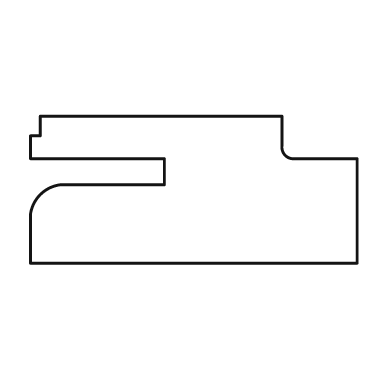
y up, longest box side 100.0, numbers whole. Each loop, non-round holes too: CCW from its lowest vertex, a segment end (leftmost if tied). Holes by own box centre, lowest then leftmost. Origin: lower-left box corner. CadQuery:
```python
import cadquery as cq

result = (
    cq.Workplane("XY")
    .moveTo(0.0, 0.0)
    .lineTo(100.0, 0.0)
    .lineTo(100.0, 32.0)
    .lineTo(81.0, 32.0)
    .threePointArc((78.0, 33.0), (77.0, 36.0))
    .lineTo(77.0, 45.0)
    .lineTo(3.0, 45.0)
    .lineTo(3.0, 39.0)
    .lineTo(0.0, 39.0)
    .lineTo(0.0, 32.0)
    .lineTo(41.0, 32.0)
    .lineTo(41.0, 24.0)
    .lineTo(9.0, 24.0)
    .threePointArc((3.0, 21.0), (0.0, 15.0))
    .close()
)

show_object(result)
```